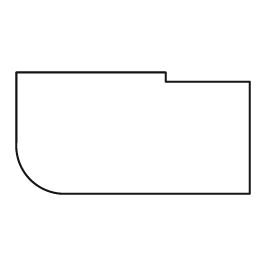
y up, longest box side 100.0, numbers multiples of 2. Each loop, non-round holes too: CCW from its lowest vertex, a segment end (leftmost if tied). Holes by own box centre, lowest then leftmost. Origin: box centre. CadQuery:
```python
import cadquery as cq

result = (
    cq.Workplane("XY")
    .moveTo(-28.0, -26.0)
    .lineTo(50.0, -26.0)
    .lineTo(50.0, 22.0)
    .lineTo(14.0, 22.0)
    .lineTo(14.0, 26.0)
    .lineTo(-50.0, 26.0)
    .lineTo(-50.0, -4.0)
    .threePointArc((-44.0, -20.0), (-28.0, -26.0))
    .close()
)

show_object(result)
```